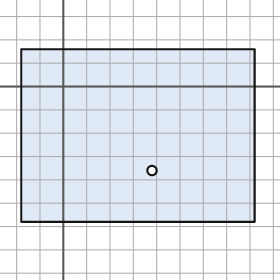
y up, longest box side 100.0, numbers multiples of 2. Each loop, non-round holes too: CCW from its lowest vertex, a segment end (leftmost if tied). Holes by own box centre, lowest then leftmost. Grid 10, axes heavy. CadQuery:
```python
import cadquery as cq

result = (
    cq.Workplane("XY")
    .moveTo(-18.0, -58.0)
    .lineTo(82.0, -58.0)
    .lineTo(82.0, 16.0)
    .lineTo(-18.0, 16.0)
    .close()
    .moveTo(38.0, -36.0)
    .circle(2.0)
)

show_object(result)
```